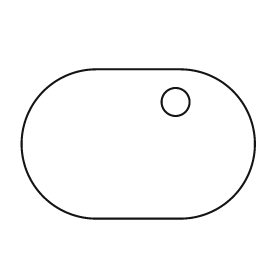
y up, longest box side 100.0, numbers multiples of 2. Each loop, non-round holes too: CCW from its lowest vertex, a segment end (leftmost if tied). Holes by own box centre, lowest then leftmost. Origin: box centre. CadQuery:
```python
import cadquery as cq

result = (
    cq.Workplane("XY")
    .moveTo(-18.0, -32.0)
    .lineTo(18.0, -32.0)
    .threePointArc((50.0, 0.0), (18.0, 32.0))
    .lineTo(-18.0, 32.0)
    .threePointArc((-50.0, 0.0), (-18.0, -32.0))
    .close()
    .moveTo(16.0, 18.0)
    .circle(6.0)
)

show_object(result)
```